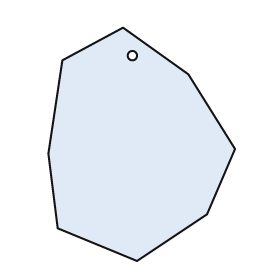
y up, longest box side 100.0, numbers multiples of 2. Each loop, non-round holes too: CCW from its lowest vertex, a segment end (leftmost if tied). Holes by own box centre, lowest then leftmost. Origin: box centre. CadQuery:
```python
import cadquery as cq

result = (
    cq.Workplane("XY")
    .moveTo(-2.0, -50.0)
    .lineTo(28.0, -30.0)
    .lineTo(40.0, -2.0)
    .lineTo(20.0, 30.0)
    .lineTo(-8.0, 50.0)
    .lineTo(-34.0, 36.0)
    .lineTo(-40.0, -4.0)
    .lineTo(-36.0, -36.0)
    .close()
    .moveTo(-4.0, 38.0)
    .circle(2.0)
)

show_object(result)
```